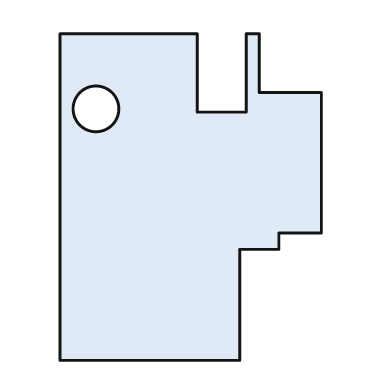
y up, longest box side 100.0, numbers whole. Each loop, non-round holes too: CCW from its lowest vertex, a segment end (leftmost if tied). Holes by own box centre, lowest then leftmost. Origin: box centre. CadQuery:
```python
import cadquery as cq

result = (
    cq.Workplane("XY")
    .moveTo(-40.0, -50.0)
    .lineTo(15.0, -50.0)
    .lineTo(15.0, -16.0)
    .lineTo(27.0, -16.0)
    .lineTo(27.0, -11.0)
    .lineTo(40.0, -11.0)
    .lineTo(40.0, 32.0)
    .lineTo(21.0, 32.0)
    .lineTo(21.0, 50.0)
    .lineTo(17.0, 50.0)
    .lineTo(17.0, 26.0)
    .lineTo(2.0, 26.0)
    .lineTo(2.0, 50.0)
    .lineTo(-40.0, 50.0)
    .close()
    .moveTo(-29.0, 27.0)
    .circle(7.0)
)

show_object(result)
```